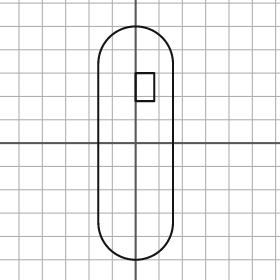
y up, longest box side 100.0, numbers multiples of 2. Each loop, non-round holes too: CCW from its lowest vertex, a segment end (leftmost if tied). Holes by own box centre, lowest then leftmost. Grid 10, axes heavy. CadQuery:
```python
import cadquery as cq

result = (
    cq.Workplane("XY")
    .moveTo(-16.0, -34.0)
    .threePointArc((0.0, -50.0), (16.0, -34.0))
    .lineTo(16.0, 34.0)
    .threePointArc((0.0, 50.0), (-16.0, 34.0))
    .close()
    .moveTo(0.0, 18.0)
    .lineTo(8.0, 18.0)
    .lineTo(8.0, 30.0)
    .lineTo(0.0, 30.0)
    .close()
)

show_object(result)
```